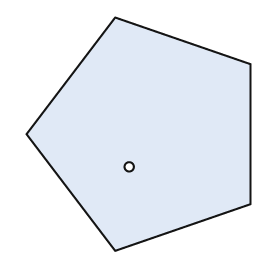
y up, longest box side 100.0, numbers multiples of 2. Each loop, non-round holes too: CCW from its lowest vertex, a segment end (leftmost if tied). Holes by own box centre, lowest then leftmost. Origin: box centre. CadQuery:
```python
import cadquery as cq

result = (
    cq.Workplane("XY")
    .moveTo(-10.0, -50.0)
    .lineTo(48.0, -30.0)
    .lineTo(48.0, 30.0)
    .lineTo(-10.0, 50.0)
    .lineTo(-48.0, 0.0)
    .close()
    .moveTo(-4.0, -14.0)
    .circle(2.0)
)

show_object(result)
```